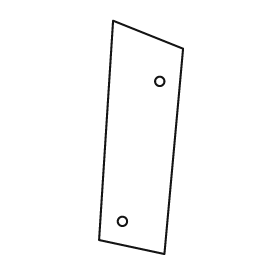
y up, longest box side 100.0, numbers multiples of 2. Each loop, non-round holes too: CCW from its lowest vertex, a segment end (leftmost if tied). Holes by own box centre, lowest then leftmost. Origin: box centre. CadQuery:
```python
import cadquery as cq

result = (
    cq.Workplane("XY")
    .moveTo(10.0, -50.0)
    .lineTo(18.0, 38.0)
    .lineTo(-12.0, 50.0)
    .lineTo(-18.0, -44.0)
    .close()
    .moveTo(-8.0, -36.0)
    .circle(2.0)
    .moveTo(8.0, 24.0)
    .circle(2.0)
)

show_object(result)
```